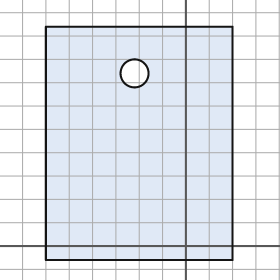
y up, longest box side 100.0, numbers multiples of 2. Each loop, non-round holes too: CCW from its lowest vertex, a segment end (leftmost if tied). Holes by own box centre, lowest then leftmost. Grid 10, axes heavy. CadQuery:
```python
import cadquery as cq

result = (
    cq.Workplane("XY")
    .moveTo(-60.0, -6.0)
    .lineTo(20.0, -6.0)
    .lineTo(20.0, 94.0)
    .lineTo(-60.0, 94.0)
    .close()
    .moveTo(-22.0, 74.0)
    .circle(6.0)
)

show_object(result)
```